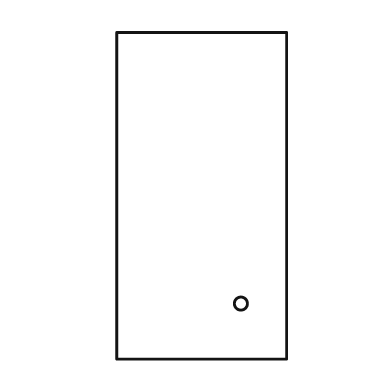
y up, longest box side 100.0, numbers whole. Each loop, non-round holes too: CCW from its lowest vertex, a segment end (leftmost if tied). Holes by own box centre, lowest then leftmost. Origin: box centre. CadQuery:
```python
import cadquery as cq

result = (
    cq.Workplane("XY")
    .moveTo(-26.0, -50.0)
    .lineTo(26.0, -50.0)
    .lineTo(26.0, 50.0)
    .lineTo(-26.0, 50.0)
    .close()
    .moveTo(12.0, -33.0)
    .circle(2.0)
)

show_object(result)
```